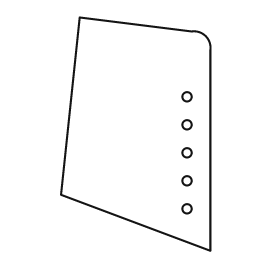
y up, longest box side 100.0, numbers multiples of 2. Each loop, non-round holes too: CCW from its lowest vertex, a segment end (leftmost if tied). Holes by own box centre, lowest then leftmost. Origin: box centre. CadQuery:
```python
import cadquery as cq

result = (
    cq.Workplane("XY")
    .moveTo(32.0, -50.0)
    .lineTo(32.0, 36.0)
    .threePointArc((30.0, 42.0), (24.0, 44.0))
    .lineTo(-24.0, 50.0)
    .lineTo(-32.0, -26.0)
    .close()
    .moveTo(22.0, -32.0)
    .circle(2.0)
    .moveTo(22.0, -20.0)
    .circle(2.0)
    .moveTo(22.0, -8.0)
    .circle(2.0)
    .moveTo(22.0, 4.0)
    .circle(2.0)
    .moveTo(22.0, 16.0)
    .circle(2.0)
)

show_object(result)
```